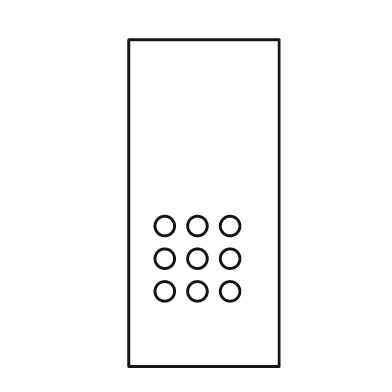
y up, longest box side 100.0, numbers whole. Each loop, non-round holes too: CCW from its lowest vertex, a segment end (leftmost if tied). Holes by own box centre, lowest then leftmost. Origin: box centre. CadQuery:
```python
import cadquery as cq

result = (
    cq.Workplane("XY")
    .moveTo(-23.0, -50.0)
    .lineTo(23.0, -50.0)
    .lineTo(23.0, 50.0)
    .lineTo(-23.0, 50.0)
    .close()
    .moveTo(-12.0, -27.0)
    .circle(3.0)
    .moveTo(-2.0, -27.0)
    .circle(3.0)
    .moveTo(8.0, -27.0)
    .circle(3.0)
    .moveTo(-12.0, -17.0)
    .circle(3.0)
    .moveTo(-2.0, -17.0)
    .circle(3.0)
    .moveTo(8.0, -17.0)
    .circle(3.0)
    .moveTo(-12.0, -7.0)
    .circle(3.0)
    .moveTo(-2.0, -7.0)
    .circle(3.0)
    .moveTo(8.0, -7.0)
    .circle(3.0)
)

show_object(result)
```